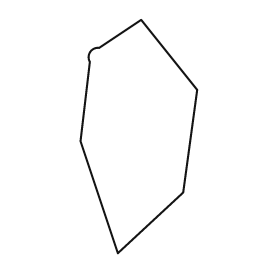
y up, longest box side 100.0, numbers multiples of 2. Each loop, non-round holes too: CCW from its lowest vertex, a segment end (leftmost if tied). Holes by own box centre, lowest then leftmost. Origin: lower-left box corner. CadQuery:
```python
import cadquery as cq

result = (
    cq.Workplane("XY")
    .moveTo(16.0, 0.0)
    .lineTo(44.0, 26.0)
    .lineTo(50.0, 70.0)
    .lineTo(26.0, 100.0)
    .lineTo(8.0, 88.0)
    .threePointArc((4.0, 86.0), (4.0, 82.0))
    .lineTo(0.0, 48.0)
    .close()
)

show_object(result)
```